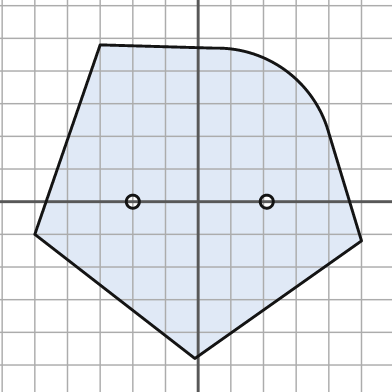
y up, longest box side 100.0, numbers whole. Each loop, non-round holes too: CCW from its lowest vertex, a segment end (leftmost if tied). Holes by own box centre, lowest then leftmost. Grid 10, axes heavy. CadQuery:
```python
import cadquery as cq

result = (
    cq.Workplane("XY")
    .moveTo(-1.0, -48.0)
    .lineTo(50.0, -12.0)
    .lineTo(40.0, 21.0)
    .threePointArc((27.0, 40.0), (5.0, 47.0))
    .lineTo(-30.0, 48.0)
    .lineTo(-50.0, -10.0)
    .close()
    .moveTo(-20.0, 0.0)
    .circle(2.0)
    .moveTo(21.0, 0.0)
    .circle(2.0)
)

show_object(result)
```